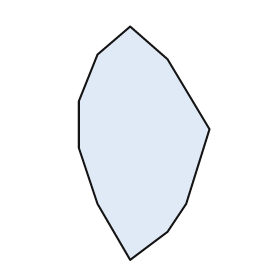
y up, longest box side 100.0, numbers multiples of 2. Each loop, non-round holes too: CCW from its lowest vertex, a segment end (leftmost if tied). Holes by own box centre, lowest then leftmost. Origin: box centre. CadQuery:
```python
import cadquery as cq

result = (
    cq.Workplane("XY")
    .moveTo(-6.0, -50.0)
    .lineTo(10.0, -38.0)
    .lineTo(18.0, -26.0)
    .lineTo(28.0, 6.0)
    .lineTo(10.0, 36.0)
    .lineTo(-6.0, 50.0)
    .lineTo(-20.0, 38.0)
    .lineTo(-28.0, 18.0)
    .lineTo(-28.0, -2.0)
    .lineTo(-20.0, -26.0)
    .close()
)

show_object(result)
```